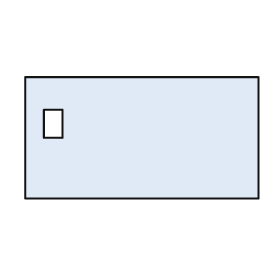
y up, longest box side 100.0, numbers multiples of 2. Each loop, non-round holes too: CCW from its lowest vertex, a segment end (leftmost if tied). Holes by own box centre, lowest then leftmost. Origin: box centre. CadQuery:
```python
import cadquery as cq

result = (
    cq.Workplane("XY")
    .moveTo(-50.0, -26.0)
    .lineTo(50.0, -26.0)
    .lineTo(50.0, 26.0)
    .lineTo(-50.0, 26.0)
    .close()
    .moveTo(-42.0, 0.0)
    .lineTo(-34.0, 0.0)
    .lineTo(-34.0, 12.0)
    .lineTo(-42.0, 12.0)
    .close()
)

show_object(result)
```